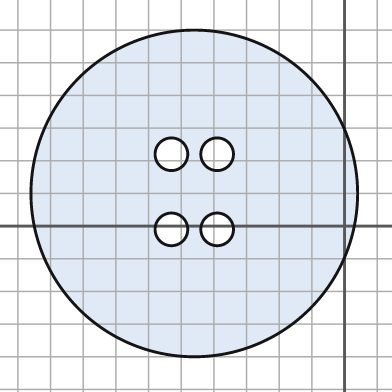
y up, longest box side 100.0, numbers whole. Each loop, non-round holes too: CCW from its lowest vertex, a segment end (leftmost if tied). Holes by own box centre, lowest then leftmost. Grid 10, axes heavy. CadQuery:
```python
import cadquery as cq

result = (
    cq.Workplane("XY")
    .moveTo(-46.0, 10.0)
    .circle(50.0)
    .moveTo(-53.0, -1.0)
    .circle(5.0)
    .moveTo(-39.0, -1.0)
    .circle(5.0)
    .moveTo(-53.0, 22.0)
    .circle(5.0)
    .moveTo(-39.0, 22.0)
    .circle(5.0)
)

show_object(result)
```